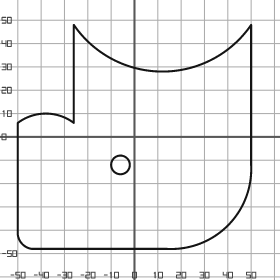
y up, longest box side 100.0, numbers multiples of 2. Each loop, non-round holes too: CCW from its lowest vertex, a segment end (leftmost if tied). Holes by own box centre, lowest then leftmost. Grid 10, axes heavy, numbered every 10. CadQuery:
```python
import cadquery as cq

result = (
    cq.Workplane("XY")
    .moveTo(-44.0, -48.0)
    .lineTo(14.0, -48.0)
    .threePointArc((40.0, -38.0), (50.0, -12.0))
    .lineTo(50.0, 48.0)
    .threePointArc((12.0, 28.0), (-26.0, 48.0))
    .lineTo(-26.0, 6.0)
    .threePointArc((-38.0, 10.0), (-50.0, 6.0))
    .lineTo(-50.0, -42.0)
    .threePointArc((-48.0, -46.0), (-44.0, -48.0))
    .close()
    .moveTo(-6.0, -12.0)
    .circle(4.0)
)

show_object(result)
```